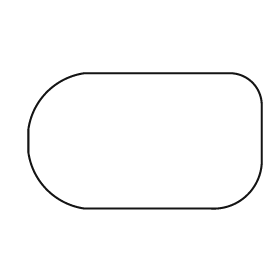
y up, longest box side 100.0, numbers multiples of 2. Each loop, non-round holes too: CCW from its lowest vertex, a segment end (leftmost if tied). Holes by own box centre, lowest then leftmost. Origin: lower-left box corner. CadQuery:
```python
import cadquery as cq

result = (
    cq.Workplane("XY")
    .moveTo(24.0, 0.0)
    .lineTo(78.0, 0.0)
    .threePointArc((94.0, 6.0), (100.0, 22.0))
    .lineTo(100.0, 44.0)
    .threePointArc((96.0, 54.0), (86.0, 58.0))
    .lineTo(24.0, 58.0)
    .threePointArc((8.0, 50.0), (0.0, 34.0))
    .lineTo(0.0, 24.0)
    .threePointArc((8.0, 8.0), (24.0, 0.0))
    .close()
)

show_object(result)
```